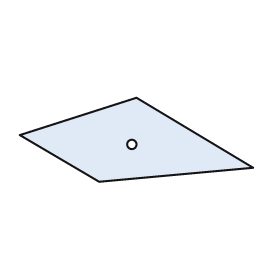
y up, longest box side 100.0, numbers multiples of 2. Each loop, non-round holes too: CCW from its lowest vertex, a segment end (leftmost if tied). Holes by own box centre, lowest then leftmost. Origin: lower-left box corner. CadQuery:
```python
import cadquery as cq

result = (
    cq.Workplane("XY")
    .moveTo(34.0, 0.0)
    .lineTo(100.0, 6.0)
    .lineTo(50.0, 36.0)
    .lineTo(0.0, 20.0)
    .close()
    .moveTo(48.0, 16.0)
    .circle(2.0)
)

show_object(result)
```